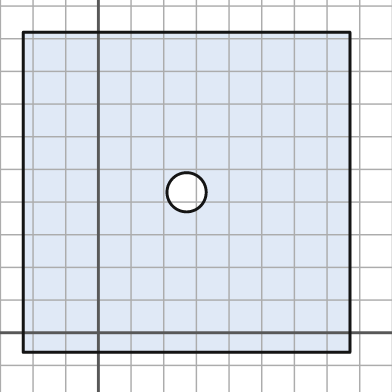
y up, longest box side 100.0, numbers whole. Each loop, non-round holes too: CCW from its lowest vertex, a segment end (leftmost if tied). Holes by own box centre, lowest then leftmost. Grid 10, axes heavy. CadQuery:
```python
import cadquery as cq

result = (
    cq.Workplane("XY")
    .moveTo(-23.0, -6.0)
    .lineTo(77.0, -6.0)
    .lineTo(77.0, 92.0)
    .lineTo(-23.0, 92.0)
    .close()
    .moveTo(27.0, 43.0)
    .circle(6.0)
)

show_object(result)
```